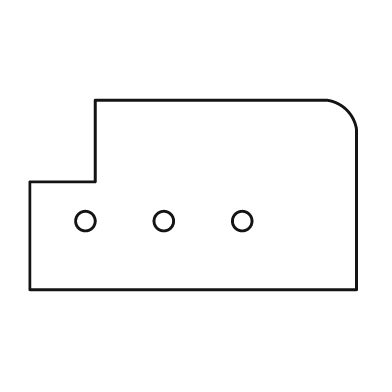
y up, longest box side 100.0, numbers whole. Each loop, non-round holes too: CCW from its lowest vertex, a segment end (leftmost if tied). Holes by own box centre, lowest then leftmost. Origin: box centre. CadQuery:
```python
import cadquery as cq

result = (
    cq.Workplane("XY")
    .moveTo(-50.0, -29.0)
    .lineTo(50.0, -29.0)
    .lineTo(50.0, 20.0)
    .threePointArc((47.0, 26.0), (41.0, 29.0))
    .lineTo(-30.0, 29.0)
    .lineTo(-30.0, 4.0)
    .lineTo(-50.0, 4.0)
    .close()
    .moveTo(-33.0, -8.0)
    .circle(3.0)
    .moveTo(-9.0, -8.0)
    .circle(3.0)
    .moveTo(15.0, -8.0)
    .circle(3.0)
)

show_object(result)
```